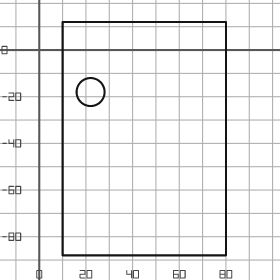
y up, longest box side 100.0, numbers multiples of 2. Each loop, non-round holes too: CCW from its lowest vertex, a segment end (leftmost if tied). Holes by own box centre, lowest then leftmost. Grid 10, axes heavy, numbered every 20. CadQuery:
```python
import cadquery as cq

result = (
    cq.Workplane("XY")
    .moveTo(10.0, -88.0)
    .lineTo(80.0, -88.0)
    .lineTo(80.0, 12.0)
    .lineTo(10.0, 12.0)
    .close()
    .moveTo(22.0, -18.0)
    .circle(6.0)
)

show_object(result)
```